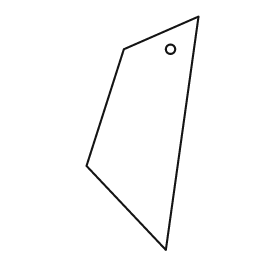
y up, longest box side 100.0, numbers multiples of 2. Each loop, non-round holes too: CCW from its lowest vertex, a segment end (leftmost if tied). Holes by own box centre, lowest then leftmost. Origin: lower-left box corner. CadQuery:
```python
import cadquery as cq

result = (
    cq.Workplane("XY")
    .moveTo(34.0, 0.0)
    .lineTo(48.0, 100.0)
    .lineTo(16.0, 86.0)
    .lineTo(0.0, 36.0)
    .close()
    .moveTo(36.0, 86.0)
    .circle(2.0)
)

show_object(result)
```